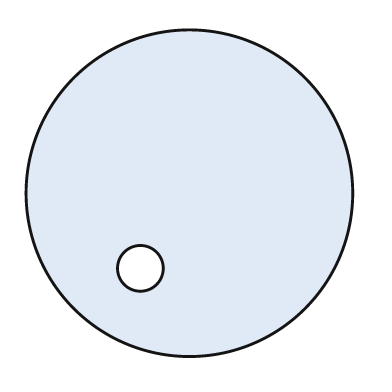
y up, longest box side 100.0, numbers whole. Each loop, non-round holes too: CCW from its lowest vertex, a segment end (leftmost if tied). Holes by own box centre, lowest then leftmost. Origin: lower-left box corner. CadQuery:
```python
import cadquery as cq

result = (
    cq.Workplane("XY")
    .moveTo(50.0, 50.0)
    .circle(50.0)
    .moveTo(35.0, 27.0)
    .circle(7.0)
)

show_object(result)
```